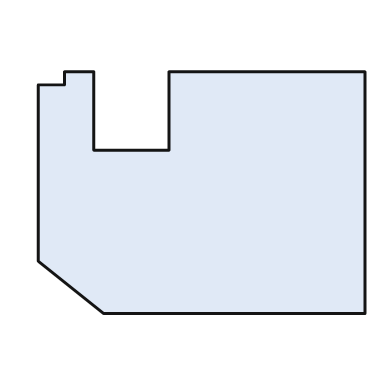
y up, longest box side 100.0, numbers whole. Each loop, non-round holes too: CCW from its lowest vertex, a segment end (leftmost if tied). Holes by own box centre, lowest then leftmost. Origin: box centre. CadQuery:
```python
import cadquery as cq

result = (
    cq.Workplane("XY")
    .moveTo(-30.0, -37.0)
    .lineTo(50.0, -37.0)
    .lineTo(50.0, 37.0)
    .lineTo(-10.0, 37.0)
    .lineTo(-10.0, 13.0)
    .lineTo(-33.0, 13.0)
    .lineTo(-33.0, 37.0)
    .lineTo(-42.0, 37.0)
    .lineTo(-42.0, 33.0)
    .lineTo(-50.0, 33.0)
    .lineTo(-50.0, -21.0)
    .close()
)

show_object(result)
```